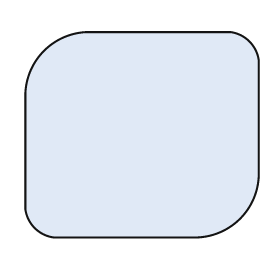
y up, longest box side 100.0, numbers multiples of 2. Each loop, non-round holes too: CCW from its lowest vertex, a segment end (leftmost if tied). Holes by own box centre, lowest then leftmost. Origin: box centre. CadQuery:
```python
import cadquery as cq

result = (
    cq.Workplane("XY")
    .moveTo(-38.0, -44.0)
    .lineTo(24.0, -44.0)
    .threePointArc((42.0, -36.0), (50.0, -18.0))
    .lineTo(50.0, 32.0)
    .threePointArc((46.0, 40.0), (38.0, 44.0))
    .lineTo(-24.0, 44.0)
    .threePointArc((-42.0, 36.0), (-50.0, 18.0))
    .lineTo(-50.0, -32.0)
    .threePointArc((-46.0, -40.0), (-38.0, -44.0))
    .close()
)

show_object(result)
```